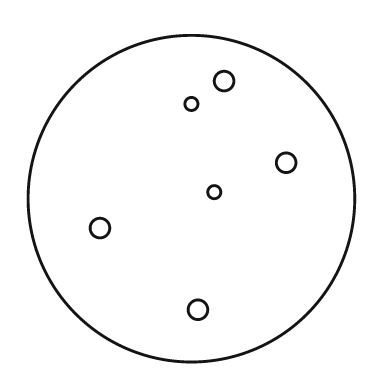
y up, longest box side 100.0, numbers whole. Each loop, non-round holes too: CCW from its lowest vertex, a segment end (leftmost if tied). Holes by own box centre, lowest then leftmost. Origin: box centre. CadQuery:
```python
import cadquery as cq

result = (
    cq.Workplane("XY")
    .moveTo(0.0, 0.0)
    .circle(50.0)
    .moveTo(2.0, -34.0)
    .circle(3.0)
    .moveTo(-28.0, -9.0)
    .circle(3.0)
    .moveTo(7.0, 2.0)
    .circle(2.0)
    .moveTo(29.0, 11.0)
    .circle(3.0)
    .moveTo(0.0, 29.0)
    .circle(2.0)
    .moveTo(10.0, 36.0)
    .circle(3.0)
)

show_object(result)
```